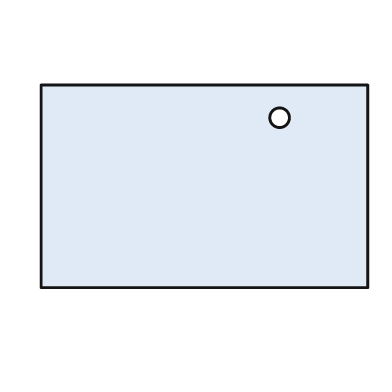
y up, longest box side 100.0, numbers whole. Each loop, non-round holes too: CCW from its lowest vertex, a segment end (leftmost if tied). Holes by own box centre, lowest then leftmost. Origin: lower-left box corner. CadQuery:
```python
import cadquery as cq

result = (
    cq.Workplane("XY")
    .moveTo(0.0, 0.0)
    .lineTo(100.0, 0.0)
    .lineTo(100.0, 62.0)
    .lineTo(0.0, 62.0)
    .close()
    .moveTo(73.0, 52.0)
    .circle(3.0)
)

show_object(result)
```